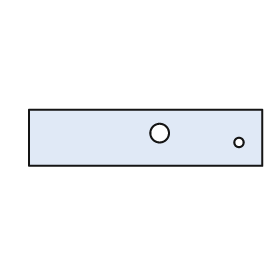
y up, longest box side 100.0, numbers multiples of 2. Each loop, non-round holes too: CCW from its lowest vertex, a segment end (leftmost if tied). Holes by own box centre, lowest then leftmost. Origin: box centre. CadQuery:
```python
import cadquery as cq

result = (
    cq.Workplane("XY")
    .moveTo(-50.0, -12.0)
    .lineTo(50.0, -12.0)
    .lineTo(50.0, 12.0)
    .lineTo(-50.0, 12.0)
    .close()
    .moveTo(40.0, -2.0)
    .circle(2.0)
    .moveTo(6.0, 2.0)
    .circle(4.0)
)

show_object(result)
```